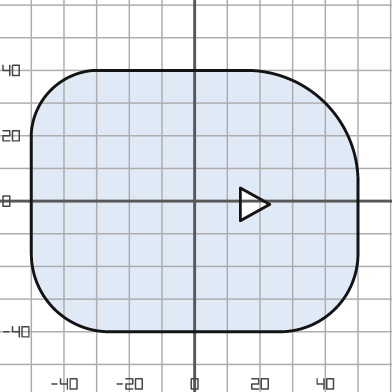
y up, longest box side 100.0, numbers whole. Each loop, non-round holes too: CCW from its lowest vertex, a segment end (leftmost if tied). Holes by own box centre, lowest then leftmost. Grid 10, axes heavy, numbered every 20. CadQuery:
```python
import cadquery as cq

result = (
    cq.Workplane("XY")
    .moveTo(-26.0, -40.0)
    .lineTo(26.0, -40.0)
    .threePointArc((43.0, -33.0), (50.0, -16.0))
    .lineTo(50.0, 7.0)
    .threePointArc((40.0, 30.0), (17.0, 40.0))
    .lineTo(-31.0, 40.0)
    .threePointArc((-44.0, 34.0), (-50.0, 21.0))
    .lineTo(-50.0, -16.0)
    .threePointArc((-43.0, -33.0), (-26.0, -40.0))
    .close()
    .moveTo(14.0, -6.0)
    .lineTo(23.0, -1.0)
    .lineTo(14.0, 4.0)
    .close()
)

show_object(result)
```